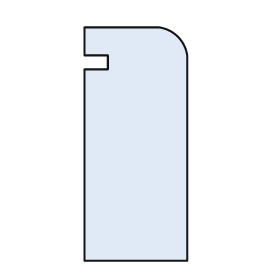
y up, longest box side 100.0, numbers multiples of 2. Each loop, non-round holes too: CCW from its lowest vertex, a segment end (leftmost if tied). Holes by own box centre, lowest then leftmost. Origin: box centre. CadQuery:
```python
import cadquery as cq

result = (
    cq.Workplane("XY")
    .moveTo(-22.0, -50.0)
    .lineTo(22.0, -50.0)
    .lineTo(22.0, 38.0)
    .threePointArc((18.0, 46.0), (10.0, 50.0))
    .lineTo(-22.0, 50.0)
    .lineTo(-22.0, 38.0)
    .lineTo(-12.0, 38.0)
    .lineTo(-12.0, 32.0)
    .lineTo(-22.0, 32.0)
    .close()
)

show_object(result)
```